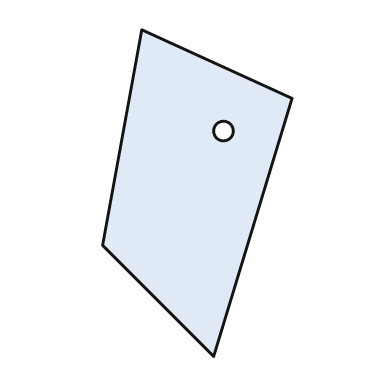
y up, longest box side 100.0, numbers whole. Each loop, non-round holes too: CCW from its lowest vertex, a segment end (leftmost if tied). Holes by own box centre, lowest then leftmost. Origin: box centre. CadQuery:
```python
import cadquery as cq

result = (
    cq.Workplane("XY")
    .moveTo(5.0, -50.0)
    .lineTo(29.0, 29.0)
    .lineTo(-17.0, 50.0)
    .lineTo(-29.0, -16.0)
    .close()
    .moveTo(8.0, 19.0)
    .circle(3.0)
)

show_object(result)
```